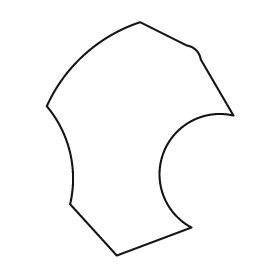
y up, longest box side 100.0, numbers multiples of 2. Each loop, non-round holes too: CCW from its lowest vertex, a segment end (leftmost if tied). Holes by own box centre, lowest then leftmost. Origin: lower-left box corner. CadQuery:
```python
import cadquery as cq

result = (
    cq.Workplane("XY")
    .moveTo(30.0, 0.0)
    .lineTo(62.0, 12.0)
    .threePointArc((50.0, 44.0), (80.0, 60.0))
    .lineTo(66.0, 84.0)
    .threePointArc((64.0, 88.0), (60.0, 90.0))
    .lineTo(40.0, 100.0)
    .threePointArc((16.0, 86.0), (0.0, 64.0))
    .threePointArc((10.0, 44.0), (10.0, 22.0))
    .close()
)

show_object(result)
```